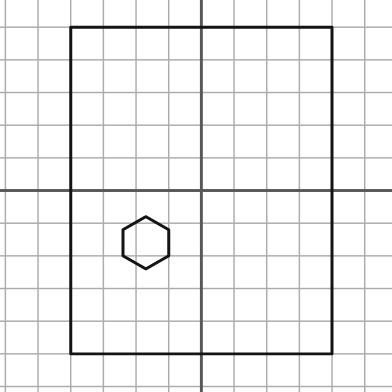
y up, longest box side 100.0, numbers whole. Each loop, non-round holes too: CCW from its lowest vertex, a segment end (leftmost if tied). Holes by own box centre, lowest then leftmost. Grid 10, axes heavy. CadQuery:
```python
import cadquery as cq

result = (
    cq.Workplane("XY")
    .moveTo(-40.0, -50.0)
    .lineTo(40.0, -50.0)
    .lineTo(40.0, 50.0)
    .lineTo(-40.0, 50.0)
    .close()
    .moveTo(-17.0, -24.0)
    .lineTo(-10.0, -20.0)
    .lineTo(-10.0, -12.0)
    .lineTo(-17.0, -8.0)
    .lineTo(-24.0, -12.0)
    .lineTo(-24.0, -20.0)
    .close()
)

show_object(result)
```